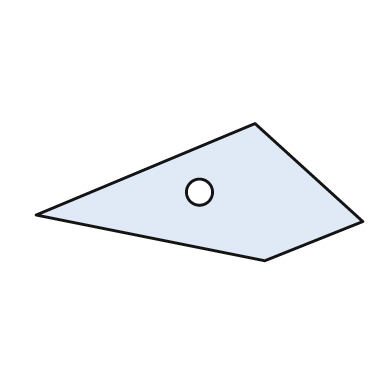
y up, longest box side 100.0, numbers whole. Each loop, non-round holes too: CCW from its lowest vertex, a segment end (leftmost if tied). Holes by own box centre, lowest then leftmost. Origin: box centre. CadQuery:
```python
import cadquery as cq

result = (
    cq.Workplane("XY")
    .moveTo(20.0, -21.0)
    .lineTo(50.0, -9.0)
    .lineTo(17.0, 21.0)
    .lineTo(-50.0, -7.0)
    .close()
    .moveTo(0.0, 0.0)
    .circle(4.0)
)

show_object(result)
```